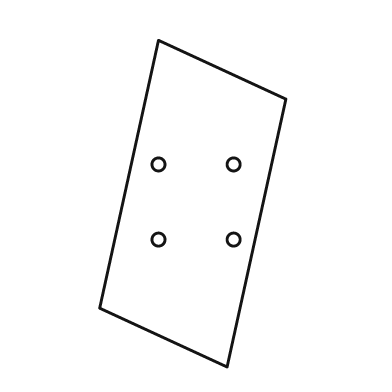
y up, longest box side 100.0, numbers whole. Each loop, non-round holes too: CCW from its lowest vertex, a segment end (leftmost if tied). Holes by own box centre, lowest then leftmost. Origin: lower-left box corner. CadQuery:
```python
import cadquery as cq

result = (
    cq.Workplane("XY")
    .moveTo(39.0, 0.0)
    .lineTo(57.0, 82.0)
    .lineTo(18.0, 100.0)
    .lineTo(0.0, 18.0)
    .close()
    .moveTo(18.0, 39.0)
    .circle(2.0)
    .moveTo(41.0, 39.0)
    .circle(2.0)
    .moveTo(18.0, 62.0)
    .circle(2.0)
    .moveTo(41.0, 62.0)
    .circle(2.0)
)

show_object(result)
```